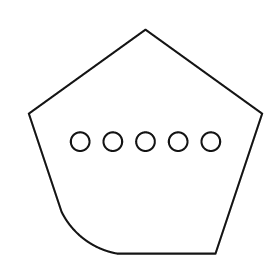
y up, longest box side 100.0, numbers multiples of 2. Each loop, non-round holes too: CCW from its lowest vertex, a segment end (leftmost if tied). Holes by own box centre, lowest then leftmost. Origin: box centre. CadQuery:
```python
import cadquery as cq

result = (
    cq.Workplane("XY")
    .moveTo(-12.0, -48.0)
    .lineTo(30.0, -48.0)
    .lineTo(50.0, 12.0)
    .lineTo(0.0, 48.0)
    .lineTo(-50.0, 12.0)
    .lineTo(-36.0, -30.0)
    .threePointArc((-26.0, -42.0), (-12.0, -48.0))
    .close()
    .moveTo(-28.0, 0.0)
    .circle(4.0)
    .moveTo(-14.0, 0.0)
    .circle(4.0)
    .moveTo(0.0, 0.0)
    .circle(4.0)
    .moveTo(14.0, 0.0)
    .circle(4.0)
    .moveTo(28.0, 0.0)
    .circle(4.0)
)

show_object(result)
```